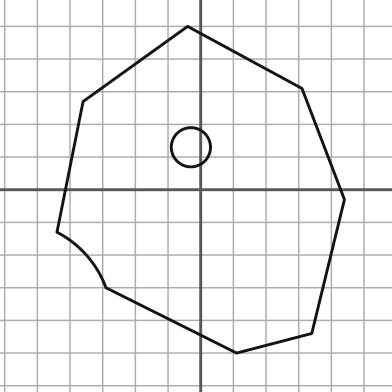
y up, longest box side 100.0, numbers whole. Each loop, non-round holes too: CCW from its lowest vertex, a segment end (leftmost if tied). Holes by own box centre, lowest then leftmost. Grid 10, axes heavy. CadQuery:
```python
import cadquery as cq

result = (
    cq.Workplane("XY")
    .moveTo(11.0, -50.0)
    .lineTo(34.0, -44.0)
    .lineTo(44.0, -3.0)
    .lineTo(31.0, 31.0)
    .lineTo(-4.0, 50.0)
    .lineTo(-36.0, 27.0)
    .lineTo(-44.0, -13.0)
    .threePointArc((-35.0, -20.0), (-29.0, -30.0))
    .close()
    .moveTo(-3.0, 13.0)
    .circle(6.0)
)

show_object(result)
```